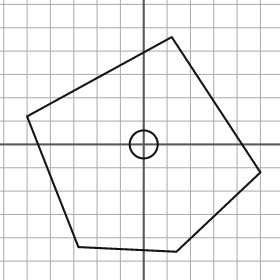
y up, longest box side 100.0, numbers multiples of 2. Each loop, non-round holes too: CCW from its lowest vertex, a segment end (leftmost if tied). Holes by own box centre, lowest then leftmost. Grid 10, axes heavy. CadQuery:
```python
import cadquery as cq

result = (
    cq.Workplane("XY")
    .moveTo(14.0, -46.0)
    .lineTo(50.0, -12.0)
    .lineTo(12.0, 46.0)
    .lineTo(-50.0, 12.0)
    .lineTo(-28.0, -44.0)
    .close()
    .moveTo(0.0, 0.0)
    .circle(6.0)
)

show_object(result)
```